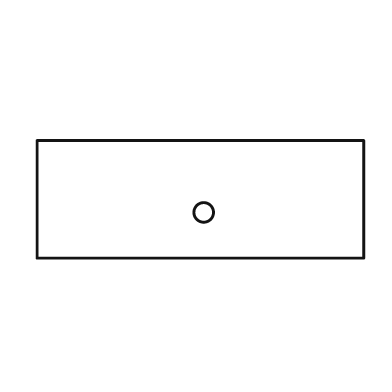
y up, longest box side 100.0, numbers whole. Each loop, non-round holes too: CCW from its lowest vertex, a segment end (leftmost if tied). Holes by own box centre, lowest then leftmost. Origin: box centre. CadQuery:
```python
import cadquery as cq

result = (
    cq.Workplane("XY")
    .moveTo(-50.0, -18.0)
    .lineTo(50.0, -18.0)
    .lineTo(50.0, 18.0)
    .lineTo(-50.0, 18.0)
    .close()
    .moveTo(1.0, -4.0)
    .circle(3.0)
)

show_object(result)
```